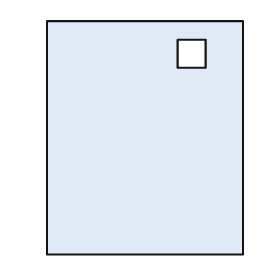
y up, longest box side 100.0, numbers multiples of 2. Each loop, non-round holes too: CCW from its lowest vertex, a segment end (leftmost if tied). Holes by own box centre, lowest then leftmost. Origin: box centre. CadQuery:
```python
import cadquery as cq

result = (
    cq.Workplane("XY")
    .moveTo(-42.0, -50.0)
    .lineTo(42.0, -50.0)
    .lineTo(42.0, 50.0)
    .lineTo(-42.0, 50.0)
    .close()
    .moveTo(14.0, 30.0)
    .lineTo(26.0, 30.0)
    .lineTo(26.0, 42.0)
    .lineTo(14.0, 42.0)
    .close()
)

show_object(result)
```